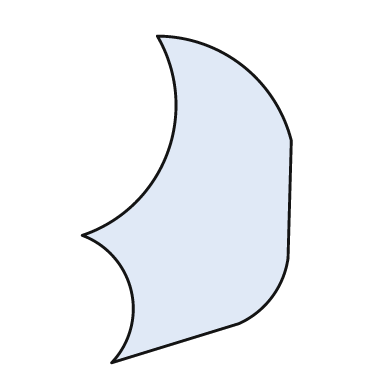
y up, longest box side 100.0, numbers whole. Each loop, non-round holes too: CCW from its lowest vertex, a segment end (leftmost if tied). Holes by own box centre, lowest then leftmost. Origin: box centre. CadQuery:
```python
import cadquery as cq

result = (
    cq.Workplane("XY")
    .moveTo(-23.0, -50.0)
    .lineTo(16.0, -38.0)
    .threePointArc((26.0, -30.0), (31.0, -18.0))
    .lineTo(32.0, 18.0)
    .threePointArc((17.0, 41.0), (-9.0, 50.0))
    .threePointArc((-6.0, 14.0), (-32.0, -11.0))
    .threePointArc((-17.0, -28.0), (-23.0, -50.0))
    .close()
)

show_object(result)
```